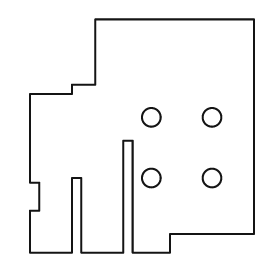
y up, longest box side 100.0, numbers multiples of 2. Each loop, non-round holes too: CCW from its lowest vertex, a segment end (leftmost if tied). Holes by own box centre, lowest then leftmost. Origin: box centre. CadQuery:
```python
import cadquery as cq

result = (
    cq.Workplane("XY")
    .moveTo(-48.0, -50.0)
    .lineTo(-30.0, -50.0)
    .lineTo(-30.0, -18.0)
    .lineTo(-26.0, -18.0)
    .lineTo(-26.0, -50.0)
    .lineTo(-8.0, -50.0)
    .lineTo(-8.0, -2.0)
    .lineTo(-4.0, -2.0)
    .lineTo(-4.0, -50.0)
    .lineTo(12.0, -50.0)
    .lineTo(12.0, -42.0)
    .lineTo(48.0, -42.0)
    .lineTo(48.0, 50.0)
    .lineTo(-20.0, 50.0)
    .lineTo(-20.0, 22.0)
    .lineTo(-30.0, 22.0)
    .lineTo(-30.0, 18.0)
    .lineTo(-48.0, 18.0)
    .lineTo(-48.0, -20.0)
    .lineTo(-44.0, -20.0)
    .lineTo(-44.0, -32.0)
    .lineTo(-48.0, -32.0)
    .close()
    .moveTo(4.0, -18.0)
    .circle(4.0)
    .moveTo(30.0, -18.0)
    .circle(4.0)
    .moveTo(4.0, 8.0)
    .circle(4.0)
    .moveTo(30.0, 8.0)
    .circle(4.0)
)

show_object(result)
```